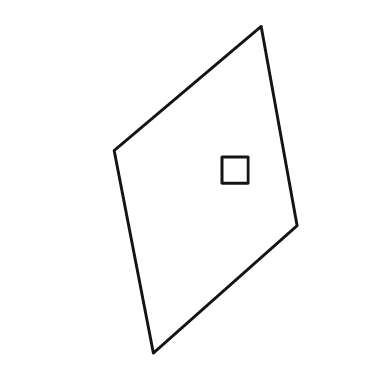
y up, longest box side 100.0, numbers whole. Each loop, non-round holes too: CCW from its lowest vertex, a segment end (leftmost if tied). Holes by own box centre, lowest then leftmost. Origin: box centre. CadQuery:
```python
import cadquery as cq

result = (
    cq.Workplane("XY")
    .moveTo(-16.0, -50.0)
    .lineTo(28.0, -11.0)
    .lineTo(17.0, 50.0)
    .lineTo(-28.0, 12.0)
    .close()
    .moveTo(5.0, 2.0)
    .lineTo(13.0, 2.0)
    .lineTo(13.0, 10.0)
    .lineTo(5.0, 10.0)
    .close()
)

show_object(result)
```